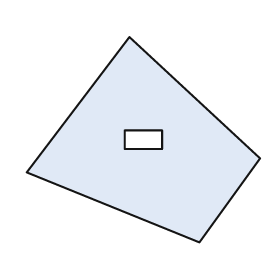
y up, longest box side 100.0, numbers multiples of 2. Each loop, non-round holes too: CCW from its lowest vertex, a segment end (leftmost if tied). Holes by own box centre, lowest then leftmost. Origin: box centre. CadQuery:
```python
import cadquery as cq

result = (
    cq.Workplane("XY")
    .moveTo(24.0, -44.0)
    .lineTo(50.0, -8.0)
    .lineTo(-6.0, 44.0)
    .lineTo(-50.0, -14.0)
    .close()
    .moveTo(-8.0, -4.0)
    .lineTo(8.0, -4.0)
    .lineTo(8.0, 4.0)
    .lineTo(-8.0, 4.0)
    .close()
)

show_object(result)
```